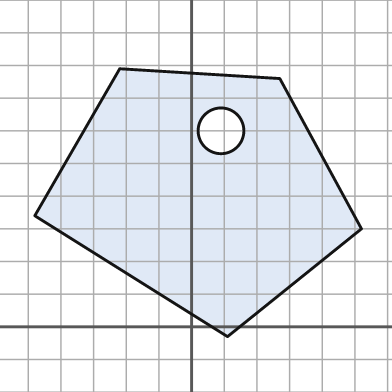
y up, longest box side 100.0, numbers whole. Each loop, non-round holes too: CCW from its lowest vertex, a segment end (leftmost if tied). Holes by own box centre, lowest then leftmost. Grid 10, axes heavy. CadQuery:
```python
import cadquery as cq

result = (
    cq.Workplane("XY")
    .moveTo(11.0, -3.0)
    .lineTo(52.0, 30.0)
    .lineTo(27.0, 76.0)
    .lineTo(-22.0, 79.0)
    .lineTo(-48.0, 34.0)
    .close()
    .moveTo(9.0, 60.0)
    .circle(7.0)
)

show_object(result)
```